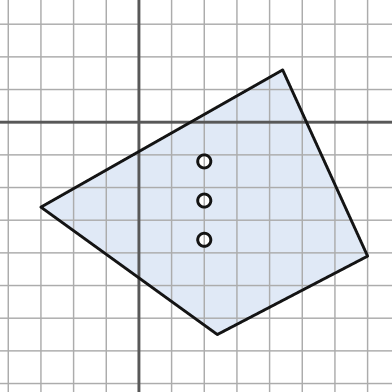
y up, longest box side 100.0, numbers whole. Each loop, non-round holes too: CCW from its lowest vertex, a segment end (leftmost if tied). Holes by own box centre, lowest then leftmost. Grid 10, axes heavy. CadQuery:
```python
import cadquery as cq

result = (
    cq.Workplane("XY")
    .moveTo(24.0, -65.0)
    .lineTo(70.0, -41.0)
    .lineTo(44.0, 16.0)
    .lineTo(-30.0, -26.0)
    .close()
    .moveTo(20.0, -36.0)
    .circle(2.0)
    .moveTo(20.0, -24.0)
    .circle(2.0)
    .moveTo(20.0, -12.0)
    .circle(2.0)
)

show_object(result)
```